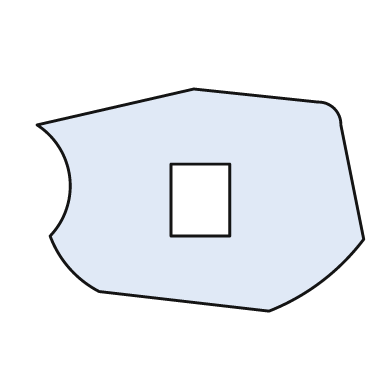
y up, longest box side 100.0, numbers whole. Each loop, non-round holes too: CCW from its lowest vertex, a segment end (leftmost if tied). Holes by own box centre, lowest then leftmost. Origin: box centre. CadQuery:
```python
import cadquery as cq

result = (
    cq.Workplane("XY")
    .moveTo(21.0, -34.0)
    .threePointArc((37.0, -25.0), (50.0, -12.0))
    .lineTo(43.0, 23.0)
    .threePointArc((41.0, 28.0), (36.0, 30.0))
    .lineTo(-2.0, 34.0)
    .lineTo(-50.0, 23.0)
    .threePointArc((-40.0, 7.0), (-46.0, -11.0))
    .threePointArc((-40.0, -21.0), (-31.0, -28.0))
    .close()
    .moveTo(-9.0, -11.0)
    .lineTo(9.0, -11.0)
    .lineTo(9.0, 11.0)
    .lineTo(-9.0, 11.0)
    .close()
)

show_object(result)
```